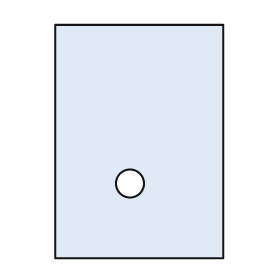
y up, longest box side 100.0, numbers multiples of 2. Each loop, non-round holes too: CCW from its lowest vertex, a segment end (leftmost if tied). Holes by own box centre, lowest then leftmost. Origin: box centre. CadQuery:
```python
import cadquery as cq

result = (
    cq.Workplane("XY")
    .moveTo(-36.0, -50.0)
    .lineTo(36.0, -50.0)
    .lineTo(36.0, 50.0)
    .lineTo(-36.0, 50.0)
    .close()
    .moveTo(-4.0, -18.0)
    .circle(6.0)
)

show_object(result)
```